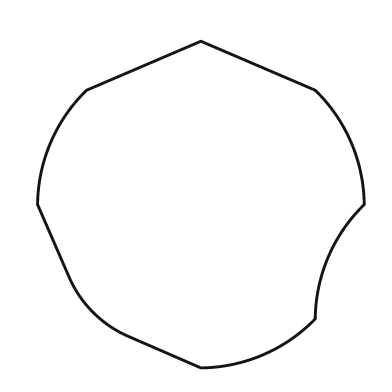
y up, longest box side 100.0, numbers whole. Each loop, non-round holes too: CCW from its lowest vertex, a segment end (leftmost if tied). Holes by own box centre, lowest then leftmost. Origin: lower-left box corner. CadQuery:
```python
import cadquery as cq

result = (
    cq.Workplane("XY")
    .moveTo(50.0, 0.0)
    .threePointArc((69.0, 4.0), (85.0, 15.0))
    .threePointArc((89.0, 34.0), (100.0, 50.0))
    .threePointArc((96.0, 69.0), (85.0, 85.0))
    .lineTo(50.0, 100.0)
    .lineTo(15.0, 85.0)
    .threePointArc((4.0, 69.0), (0.0, 50.0))
    .lineTo(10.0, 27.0)
    .threePointArc((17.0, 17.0), (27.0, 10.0))
    .close()
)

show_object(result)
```